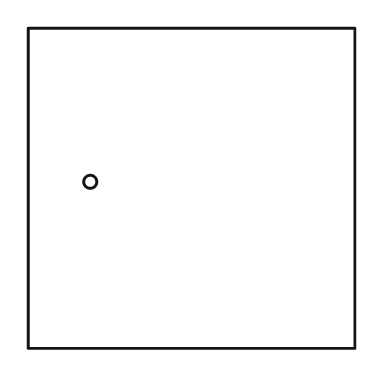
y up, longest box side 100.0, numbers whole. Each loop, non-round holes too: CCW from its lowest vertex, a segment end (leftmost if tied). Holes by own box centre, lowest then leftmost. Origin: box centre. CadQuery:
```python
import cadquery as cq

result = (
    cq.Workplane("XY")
    .moveTo(-50.0, -49.0)
    .lineTo(50.0, -49.0)
    .lineTo(50.0, 49.0)
    .lineTo(-50.0, 49.0)
    .close()
    .moveTo(-31.0, 2.0)
    .circle(2.0)
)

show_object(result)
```